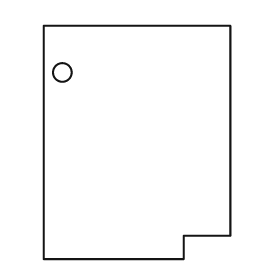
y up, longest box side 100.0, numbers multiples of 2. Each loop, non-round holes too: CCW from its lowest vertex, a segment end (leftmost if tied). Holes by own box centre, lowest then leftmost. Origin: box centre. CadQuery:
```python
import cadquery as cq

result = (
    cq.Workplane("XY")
    .moveTo(-40.0, -50.0)
    .lineTo(20.0, -50.0)
    .lineTo(20.0, -40.0)
    .lineTo(40.0, -40.0)
    .lineTo(40.0, 50.0)
    .lineTo(-40.0, 50.0)
    .close()
    .moveTo(-32.0, 30.0)
    .circle(4.0)
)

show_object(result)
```